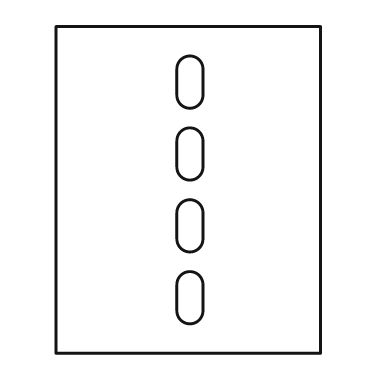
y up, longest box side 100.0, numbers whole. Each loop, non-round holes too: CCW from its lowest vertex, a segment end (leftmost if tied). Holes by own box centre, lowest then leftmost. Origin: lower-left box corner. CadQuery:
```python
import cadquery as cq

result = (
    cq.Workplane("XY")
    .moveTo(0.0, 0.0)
    .lineTo(81.0, 0.0)
    .lineTo(81.0, 100.0)
    .lineTo(0.0, 100.0)
    .close()
    .moveTo(37.0, 13.0)
    .threePointArc((41.0, 9.0), (45.0, 13.0))
    .lineTo(45.0, 21.0)
    .threePointArc((41.0, 25.0), (37.0, 21.0))
    .close()
    .moveTo(37.0, 35.0)
    .threePointArc((41.0, 31.0), (45.0, 35.0))
    .lineTo(45.0, 43.0)
    .threePointArc((41.0, 47.0), (37.0, 43.0))
    .close()
    .moveTo(37.0, 57.0)
    .threePointArc((41.0, 53.0), (45.0, 57.0))
    .lineTo(45.0, 65.0)
    .threePointArc((41.0, 69.0), (37.0, 65.0))
    .close()
    .moveTo(37.0, 79.0)
    .threePointArc((41.0, 75.0), (45.0, 79.0))
    .lineTo(45.0, 87.0)
    .threePointArc((41.0, 91.0), (37.0, 87.0))
    .close()
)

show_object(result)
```